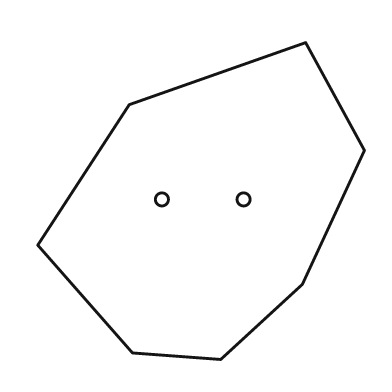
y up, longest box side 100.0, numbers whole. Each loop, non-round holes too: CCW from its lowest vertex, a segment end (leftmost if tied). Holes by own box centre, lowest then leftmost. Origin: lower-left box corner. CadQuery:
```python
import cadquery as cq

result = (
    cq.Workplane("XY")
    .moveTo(56.0, 0.0)
    .lineTo(81.0, 23.0)
    .lineTo(100.0, 64.0)
    .lineTo(82.0, 97.0)
    .lineTo(28.0, 78.0)
    .lineTo(0.0, 35.0)
    .lineTo(29.0, 2.0)
    .close()
    .moveTo(38.0, 49.0)
    .circle(2.0)
    .moveTo(63.0, 49.0)
    .circle(2.0)
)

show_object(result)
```